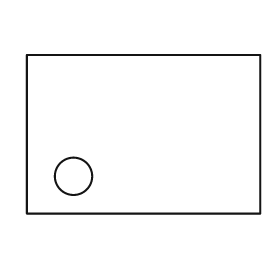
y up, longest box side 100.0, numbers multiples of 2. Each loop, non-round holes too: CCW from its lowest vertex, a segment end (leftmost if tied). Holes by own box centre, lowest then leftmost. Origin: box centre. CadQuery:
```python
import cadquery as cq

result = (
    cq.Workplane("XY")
    .moveTo(-50.0, -34.0)
    .lineTo(50.0, -34.0)
    .lineTo(50.0, 34.0)
    .lineTo(-50.0, 34.0)
    .close()
    .moveTo(-30.0, -18.0)
    .circle(8.0)
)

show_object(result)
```